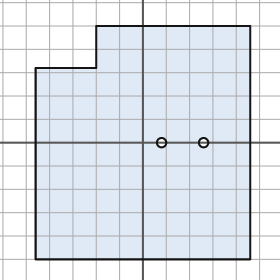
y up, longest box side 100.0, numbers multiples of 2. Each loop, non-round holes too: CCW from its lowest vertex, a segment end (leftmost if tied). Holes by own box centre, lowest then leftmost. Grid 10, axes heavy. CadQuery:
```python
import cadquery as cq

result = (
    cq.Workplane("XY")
    .moveTo(-46.0, -50.0)
    .lineTo(46.0, -50.0)
    .lineTo(46.0, 50.0)
    .lineTo(-20.0, 50.0)
    .lineTo(-20.0, 32.0)
    .lineTo(-46.0, 32.0)
    .close()
    .moveTo(8.0, 0.0)
    .circle(2.0)
    .moveTo(26.0, 0.0)
    .circle(2.0)
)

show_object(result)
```